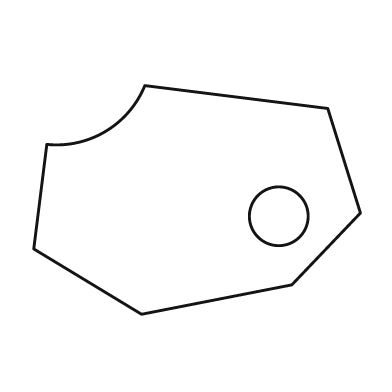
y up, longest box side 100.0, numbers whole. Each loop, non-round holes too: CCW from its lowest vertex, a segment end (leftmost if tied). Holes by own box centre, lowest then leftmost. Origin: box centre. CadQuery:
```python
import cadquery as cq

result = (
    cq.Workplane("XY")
    .moveTo(-17.0, -35.0)
    .lineTo(29.0, -26.0)
    .lineTo(50.0, -4.0)
    .lineTo(40.0, 28.0)
    .lineTo(-16.0, 35.0)
    .threePointArc((-28.0, 21.0), (-46.0, 17.0))
    .lineTo(-50.0, -15.0)
    .close()
    .moveTo(25.0, -5.0)
    .circle(9.0)
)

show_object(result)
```